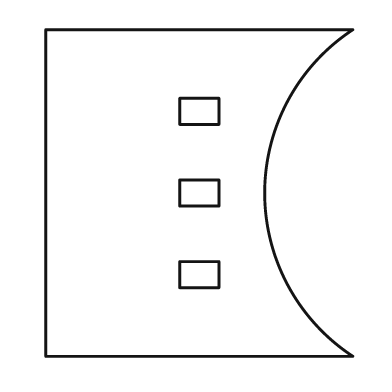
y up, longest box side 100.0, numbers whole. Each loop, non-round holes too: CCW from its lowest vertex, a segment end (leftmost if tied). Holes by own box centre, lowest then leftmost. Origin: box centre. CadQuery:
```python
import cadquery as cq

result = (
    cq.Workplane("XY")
    .moveTo(-47.0, -50.0)
    .lineTo(47.0, -50.0)
    .threePointArc((20.0, 0.0), (47.0, 50.0))
    .lineTo(-47.0, 50.0)
    .close()
    .moveTo(-6.0, -29.0)
    .lineTo(6.0, -29.0)
    .lineTo(6.0, -21.0)
    .lineTo(-6.0, -21.0)
    .close()
    .moveTo(-6.0, -4.0)
    .lineTo(6.0, -4.0)
    .lineTo(6.0, 4.0)
    .lineTo(-6.0, 4.0)
    .close()
    .moveTo(-6.0, 21.0)
    .lineTo(6.0, 21.0)
    .lineTo(6.0, 29.0)
    .lineTo(-6.0, 29.0)
    .close()
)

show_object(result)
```